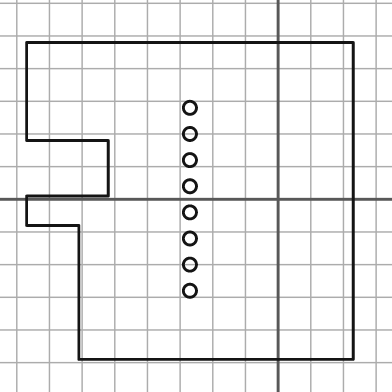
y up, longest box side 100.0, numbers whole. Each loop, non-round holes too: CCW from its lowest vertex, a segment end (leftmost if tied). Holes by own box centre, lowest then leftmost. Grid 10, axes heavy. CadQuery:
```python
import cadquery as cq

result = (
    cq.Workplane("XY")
    .moveTo(-61.0, -49.0)
    .lineTo(23.0, -49.0)
    .lineTo(23.0, 48.0)
    .lineTo(-77.0, 48.0)
    .lineTo(-77.0, 18.0)
    .lineTo(-52.0, 18.0)
    .lineTo(-52.0, 1.0)
    .lineTo(-77.0, 1.0)
    .lineTo(-77.0, -8.0)
    .lineTo(-61.0, -8.0)
    .close()
    .moveTo(-27.0, -28.0)
    .circle(2.0)
    .moveTo(-27.0, -20.0)
    .circle(2.0)
    .moveTo(-27.0, -12.0)
    .circle(2.0)
    .moveTo(-27.0, -4.0)
    .circle(2.0)
    .moveTo(-27.0, 4.0)
    .circle(2.0)
    .moveTo(-27.0, 12.0)
    .circle(2.0)
    .moveTo(-27.0, 20.0)
    .circle(2.0)
    .moveTo(-27.0, 28.0)
    .circle(2.0)
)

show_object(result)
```